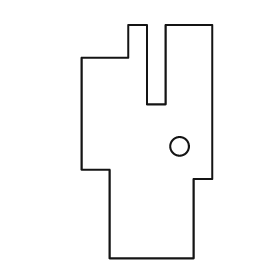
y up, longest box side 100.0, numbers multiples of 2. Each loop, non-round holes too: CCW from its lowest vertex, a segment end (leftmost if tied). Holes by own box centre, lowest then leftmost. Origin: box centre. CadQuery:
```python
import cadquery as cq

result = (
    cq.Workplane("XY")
    .moveTo(-16.0, -50.0)
    .lineTo(20.0, -50.0)
    .lineTo(20.0, -16.0)
    .lineTo(28.0, -16.0)
    .lineTo(28.0, 50.0)
    .lineTo(8.0, 50.0)
    .lineTo(8.0, 16.0)
    .lineTo(0.0, 16.0)
    .lineTo(0.0, 50.0)
    .lineTo(-8.0, 50.0)
    .lineTo(-8.0, 36.0)
    .lineTo(-28.0, 36.0)
    .lineTo(-28.0, -12.0)
    .lineTo(-16.0, -12.0)
    .close()
    .moveTo(14.0, -2.0)
    .circle(4.0)
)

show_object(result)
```